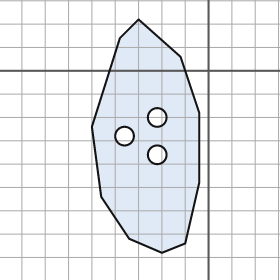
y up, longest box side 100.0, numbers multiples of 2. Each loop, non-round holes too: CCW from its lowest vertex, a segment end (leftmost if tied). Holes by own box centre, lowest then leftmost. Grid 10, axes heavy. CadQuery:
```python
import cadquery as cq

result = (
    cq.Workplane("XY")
    .moveTo(-20.0, -78.0)
    .lineTo(-10.0, -74.0)
    .lineTo(-4.0, -48.0)
    .lineTo(-4.0, -18.0)
    .lineTo(-12.0, 6.0)
    .lineTo(-30.0, 22.0)
    .lineTo(-38.0, 14.0)
    .lineTo(-50.0, -24.0)
    .lineTo(-46.0, -54.0)
    .lineTo(-34.0, -72.0)
    .close()
    .moveTo(-22.0, -36.0)
    .circle(4.0)
    .moveTo(-36.0, -28.0)
    .circle(4.0)
    .moveTo(-22.0, -20.0)
    .circle(4.0)
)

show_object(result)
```